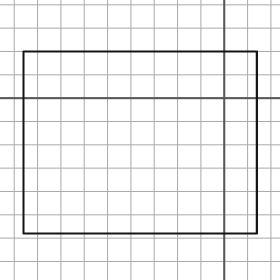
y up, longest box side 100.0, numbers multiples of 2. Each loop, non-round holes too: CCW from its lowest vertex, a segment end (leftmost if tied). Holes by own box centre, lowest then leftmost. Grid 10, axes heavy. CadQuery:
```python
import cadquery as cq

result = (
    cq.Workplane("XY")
    .moveTo(-86.0, -58.0)
    .lineTo(14.0, -58.0)
    .lineTo(14.0, 20.0)
    .lineTo(-86.0, 20.0)
    .close()
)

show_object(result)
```